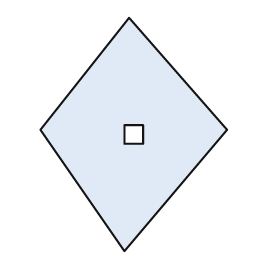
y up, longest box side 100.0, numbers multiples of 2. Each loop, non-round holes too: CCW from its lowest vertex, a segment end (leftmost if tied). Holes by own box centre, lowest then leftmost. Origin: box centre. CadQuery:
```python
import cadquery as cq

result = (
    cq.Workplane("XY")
    .moveTo(-4.0, -50.0)
    .lineTo(40.0, 2.0)
    .lineTo(-2.0, 50.0)
    .lineTo(-40.0, 2.0)
    .close()
    .moveTo(-4.0, -4.0)
    .lineTo(4.0, -4.0)
    .lineTo(4.0, 4.0)
    .lineTo(-4.0, 4.0)
    .close()
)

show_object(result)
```